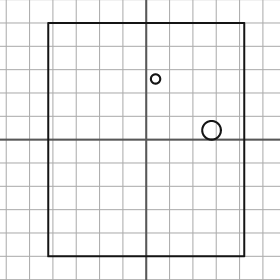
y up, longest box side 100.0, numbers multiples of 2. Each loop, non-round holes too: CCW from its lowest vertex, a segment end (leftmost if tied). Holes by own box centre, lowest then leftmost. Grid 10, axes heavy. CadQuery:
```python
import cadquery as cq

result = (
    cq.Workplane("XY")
    .moveTo(-42.0, -50.0)
    .lineTo(42.0, -50.0)
    .lineTo(42.0, 50.0)
    .lineTo(-42.0, 50.0)
    .close()
    .moveTo(28.0, 4.0)
    .circle(4.0)
    .moveTo(4.0, 26.0)
    .circle(2.0)
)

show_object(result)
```